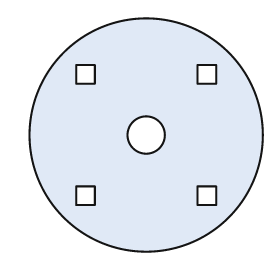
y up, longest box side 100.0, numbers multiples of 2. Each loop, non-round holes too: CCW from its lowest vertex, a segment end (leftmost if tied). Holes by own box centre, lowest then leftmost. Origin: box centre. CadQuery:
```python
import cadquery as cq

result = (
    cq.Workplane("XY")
    .moveTo(0.0, 0.0)
    .circle(50.0)
    .moveTo(-30.0, -30.0)
    .lineTo(-22.0, -30.0)
    .lineTo(-22.0, -22.0)
    .lineTo(-30.0, -22.0)
    .close()
    .moveTo(22.0, -30.0)
    .lineTo(30.0, -30.0)
    .lineTo(30.0, -22.0)
    .lineTo(22.0, -22.0)
    .close()
    .moveTo(0.0, 0.0)
    .circle(8.0)
    .moveTo(-30.0, 22.0)
    .lineTo(-22.0, 22.0)
    .lineTo(-22.0, 30.0)
    .lineTo(-30.0, 30.0)
    .close()
    .moveTo(22.0, 22.0)
    .lineTo(30.0, 22.0)
    .lineTo(30.0, 30.0)
    .lineTo(22.0, 30.0)
    .close()
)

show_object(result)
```